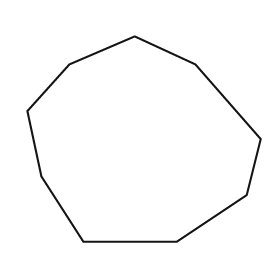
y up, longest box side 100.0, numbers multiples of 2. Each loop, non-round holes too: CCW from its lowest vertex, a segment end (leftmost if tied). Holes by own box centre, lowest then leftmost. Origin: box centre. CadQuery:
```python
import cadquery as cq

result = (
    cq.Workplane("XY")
    .moveTo(-26.0, -44.0)
    .lineTo(14.0, -44.0)
    .lineTo(44.0, -24.0)
    .lineTo(50.0, 0.0)
    .lineTo(22.0, 32.0)
    .lineTo(-4.0, 44.0)
    .lineTo(-32.0, 32.0)
    .lineTo(-50.0, 12.0)
    .lineTo(-44.0, -16.0)
    .close()
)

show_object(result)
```